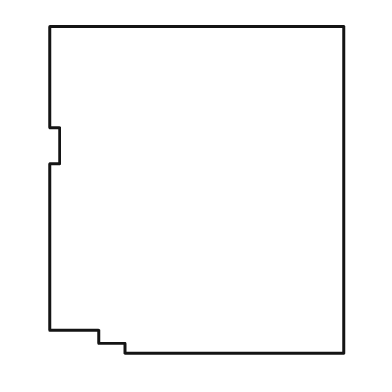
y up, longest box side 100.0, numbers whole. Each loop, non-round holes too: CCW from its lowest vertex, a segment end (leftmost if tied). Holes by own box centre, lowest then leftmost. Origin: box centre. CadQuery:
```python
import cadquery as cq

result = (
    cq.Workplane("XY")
    .moveTo(-22.0, -50.0)
    .lineTo(45.0, -50.0)
    .lineTo(45.0, 50.0)
    .lineTo(-45.0, 50.0)
    .lineTo(-45.0, 19.0)
    .lineTo(-42.0, 19.0)
    .lineTo(-42.0, 8.0)
    .lineTo(-45.0, 8.0)
    .lineTo(-45.0, -43.0)
    .lineTo(-30.0, -43.0)
    .lineTo(-30.0, -47.0)
    .lineTo(-22.0, -47.0)
    .close()
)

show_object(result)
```